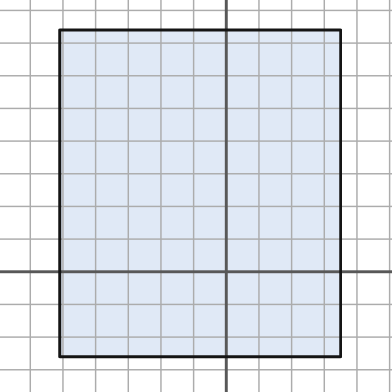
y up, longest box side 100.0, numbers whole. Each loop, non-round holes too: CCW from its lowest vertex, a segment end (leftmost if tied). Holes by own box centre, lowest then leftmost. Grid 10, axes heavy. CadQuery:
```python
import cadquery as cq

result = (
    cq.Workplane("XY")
    .moveTo(-51.0, -26.0)
    .lineTo(35.0, -26.0)
    .lineTo(35.0, 74.0)
    .lineTo(-51.0, 74.0)
    .close()
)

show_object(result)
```